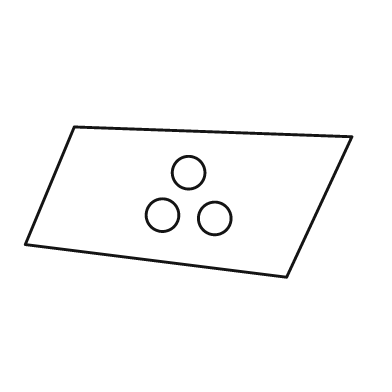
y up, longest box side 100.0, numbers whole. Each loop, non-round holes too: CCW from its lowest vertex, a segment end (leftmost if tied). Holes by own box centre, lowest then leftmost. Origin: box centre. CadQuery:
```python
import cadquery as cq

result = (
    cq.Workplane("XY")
    .moveTo(30.0, -23.0)
    .lineTo(50.0, 20.0)
    .lineTo(-35.0, 23.0)
    .lineTo(-50.0, -13.0)
    .close()
    .moveTo(8.0, -5.0)
    .circle(5.0)
    .moveTo(-8.0, -4.0)
    .circle(5.0)
    .moveTo(0.0, 9.0)
    .circle(5.0)
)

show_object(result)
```